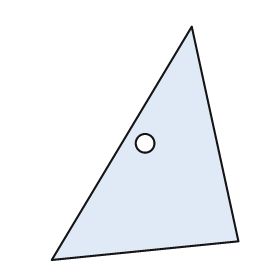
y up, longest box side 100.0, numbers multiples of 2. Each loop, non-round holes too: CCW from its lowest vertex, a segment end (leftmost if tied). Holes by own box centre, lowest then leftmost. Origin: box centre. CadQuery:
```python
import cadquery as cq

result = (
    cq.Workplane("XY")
    .moveTo(-40.0, -50.0)
    .lineTo(40.0, -42.0)
    .lineTo(20.0, 50.0)
    .close()
    .moveTo(0.0, 0.0)
    .circle(4.0)
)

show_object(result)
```